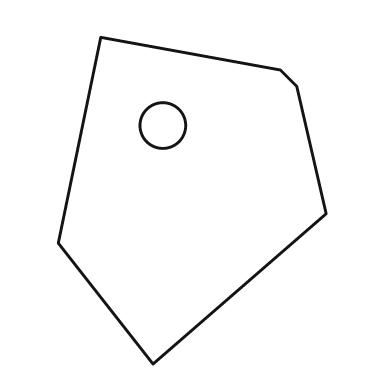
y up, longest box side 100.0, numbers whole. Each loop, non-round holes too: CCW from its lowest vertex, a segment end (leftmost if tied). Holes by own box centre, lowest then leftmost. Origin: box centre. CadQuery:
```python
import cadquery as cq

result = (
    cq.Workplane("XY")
    .moveTo(-12.0, -50.0)
    .lineTo(41.0, -4.0)
    .lineTo(32.0, 35.0)
    .lineTo(27.0, 40.0)
    .lineTo(-28.0, 50.0)
    .lineTo(-41.0, -13.0)
    .close()
    .moveTo(-9.0, 23.0)
    .circle(7.0)
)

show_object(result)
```